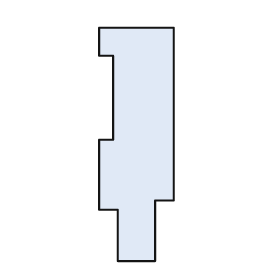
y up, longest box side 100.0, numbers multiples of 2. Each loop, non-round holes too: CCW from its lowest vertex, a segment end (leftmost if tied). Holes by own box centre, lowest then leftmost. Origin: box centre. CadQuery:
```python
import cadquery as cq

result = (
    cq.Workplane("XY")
    .moveTo(-8.0, -50.0)
    .lineTo(8.0, -50.0)
    .lineTo(8.0, -24.0)
    .lineTo(16.0, -24.0)
    .lineTo(16.0, 50.0)
    .lineTo(-16.0, 50.0)
    .lineTo(-16.0, 38.0)
    .lineTo(-10.0, 38.0)
    .lineTo(-10.0, 2.0)
    .lineTo(-16.0, 2.0)
    .lineTo(-16.0, -28.0)
    .lineTo(-8.0, -28.0)
    .close()
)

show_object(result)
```